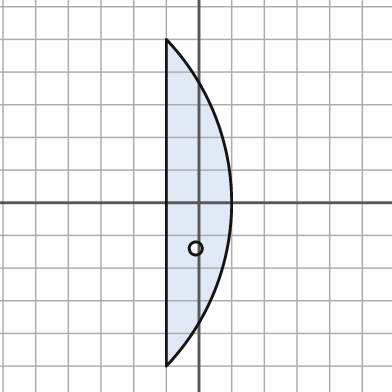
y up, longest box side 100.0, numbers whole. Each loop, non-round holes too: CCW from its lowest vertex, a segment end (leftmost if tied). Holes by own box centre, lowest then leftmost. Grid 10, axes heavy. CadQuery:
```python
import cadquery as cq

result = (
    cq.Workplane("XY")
    .moveTo(-10.0, -50.0)
    .threePointArc((10.0, 0.0), (-10.0, 50.0))
    .close()
    .moveTo(-1.0, -14.0)
    .circle(2.0)
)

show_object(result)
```